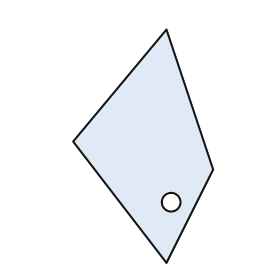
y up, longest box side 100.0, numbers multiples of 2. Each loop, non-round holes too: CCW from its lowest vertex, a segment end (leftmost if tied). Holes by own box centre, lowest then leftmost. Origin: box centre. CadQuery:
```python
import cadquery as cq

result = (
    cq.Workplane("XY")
    .moveTo(10.0, -50.0)
    .lineTo(30.0, -10.0)
    .lineTo(10.0, 50.0)
    .lineTo(-30.0, 2.0)
    .close()
    .moveTo(12.0, -24.0)
    .circle(4.0)
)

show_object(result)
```